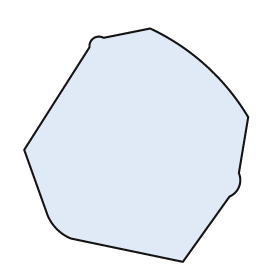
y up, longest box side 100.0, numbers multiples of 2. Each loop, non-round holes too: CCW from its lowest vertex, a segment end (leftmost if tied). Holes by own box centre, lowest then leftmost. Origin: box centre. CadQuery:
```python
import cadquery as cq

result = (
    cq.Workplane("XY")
    .moveTo(20.0, -50.0)
    .lineTo(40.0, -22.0)
    .threePointArc((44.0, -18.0), (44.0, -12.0))
    .lineTo(48.0, 12.0)
    .threePointArc((30.0, 34.0), (6.0, 50.0))
    .lineTo(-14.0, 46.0)
    .threePointArc((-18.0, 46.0), (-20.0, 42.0))
    .lineTo(-48.0, -2.0)
    .lineTo(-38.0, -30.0)
    .threePointArc((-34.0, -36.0), (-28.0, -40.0))
    .close()
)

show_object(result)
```